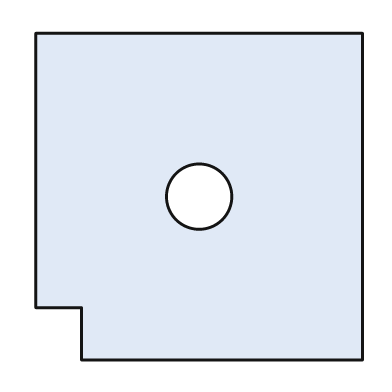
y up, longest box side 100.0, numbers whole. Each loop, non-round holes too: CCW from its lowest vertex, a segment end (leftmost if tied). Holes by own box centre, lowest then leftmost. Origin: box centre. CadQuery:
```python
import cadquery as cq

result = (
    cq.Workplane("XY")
    .moveTo(-36.0, -50.0)
    .lineTo(50.0, -50.0)
    .lineTo(50.0, 50.0)
    .lineTo(-50.0, 50.0)
    .lineTo(-50.0, -34.0)
    .lineTo(-36.0, -34.0)
    .close()
    .moveTo(0.0, 0.0)
    .circle(10.0)
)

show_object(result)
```